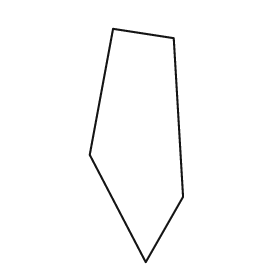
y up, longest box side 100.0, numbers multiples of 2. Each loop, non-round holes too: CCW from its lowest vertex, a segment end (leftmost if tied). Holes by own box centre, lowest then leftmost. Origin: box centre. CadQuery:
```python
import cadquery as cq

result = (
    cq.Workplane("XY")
    .moveTo(4.0, -50.0)
    .lineTo(20.0, -22.0)
    .lineTo(16.0, 46.0)
    .lineTo(-10.0, 50.0)
    .lineTo(-20.0, -4.0)
    .close()
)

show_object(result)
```